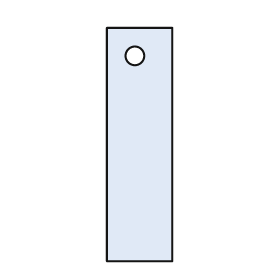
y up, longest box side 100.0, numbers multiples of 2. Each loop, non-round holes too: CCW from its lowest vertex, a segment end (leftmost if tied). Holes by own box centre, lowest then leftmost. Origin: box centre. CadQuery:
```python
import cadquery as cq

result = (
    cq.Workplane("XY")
    .moveTo(-14.0, -50.0)
    .lineTo(14.0, -50.0)
    .lineTo(14.0, 50.0)
    .lineTo(-14.0, 50.0)
    .close()
    .moveTo(-2.0, 38.0)
    .circle(4.0)
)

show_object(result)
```